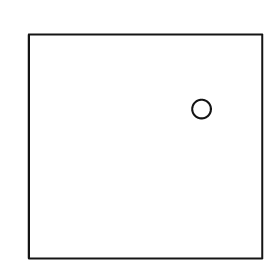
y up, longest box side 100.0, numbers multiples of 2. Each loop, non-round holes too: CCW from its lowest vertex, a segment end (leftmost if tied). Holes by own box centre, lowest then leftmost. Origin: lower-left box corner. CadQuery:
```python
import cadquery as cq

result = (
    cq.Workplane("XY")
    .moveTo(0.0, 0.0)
    .lineTo(100.0, 0.0)
    .lineTo(100.0, 96.0)
    .lineTo(0.0, 96.0)
    .close()
    .moveTo(74.0, 64.0)
    .circle(4.0)
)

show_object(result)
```